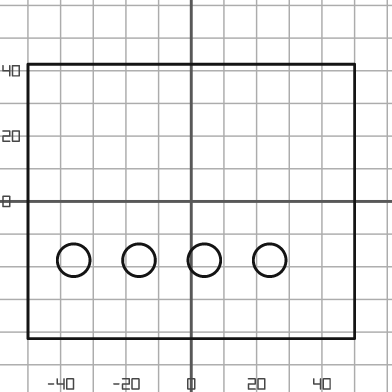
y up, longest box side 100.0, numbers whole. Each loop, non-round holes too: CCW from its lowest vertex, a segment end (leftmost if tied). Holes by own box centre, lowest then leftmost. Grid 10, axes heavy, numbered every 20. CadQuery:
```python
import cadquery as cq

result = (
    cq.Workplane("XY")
    .moveTo(-50.0, -42.0)
    .lineTo(50.0, -42.0)
    .lineTo(50.0, 42.0)
    .lineTo(-50.0, 42.0)
    .close()
    .moveTo(-36.0, -18.0)
    .circle(5.0)
    .moveTo(-16.0, -18.0)
    .circle(5.0)
    .moveTo(4.0, -18.0)
    .circle(5.0)
    .moveTo(24.0, -18.0)
    .circle(5.0)
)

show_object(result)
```